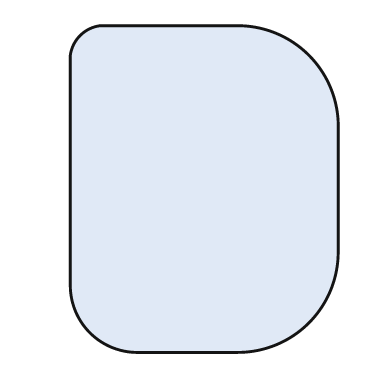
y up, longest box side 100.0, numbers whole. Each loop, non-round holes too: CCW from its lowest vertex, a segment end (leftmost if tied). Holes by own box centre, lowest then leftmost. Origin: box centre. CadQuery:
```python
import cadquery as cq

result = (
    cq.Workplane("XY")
    .moveTo(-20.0, -50.0)
    .lineTo(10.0, -50.0)
    .threePointArc((32.0, -41.0), (41.0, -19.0))
    .lineTo(41.0, 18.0)
    .threePointArc((32.0, 41.0), (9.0, 50.0))
    .lineTo(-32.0, 50.0)
    .threePointArc((-38.0, 47.0), (-41.0, 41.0))
    .lineTo(-41.0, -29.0)
    .threePointArc((-35.0, -44.0), (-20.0, -50.0))
    .close()
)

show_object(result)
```